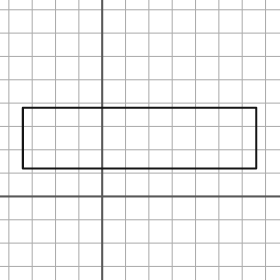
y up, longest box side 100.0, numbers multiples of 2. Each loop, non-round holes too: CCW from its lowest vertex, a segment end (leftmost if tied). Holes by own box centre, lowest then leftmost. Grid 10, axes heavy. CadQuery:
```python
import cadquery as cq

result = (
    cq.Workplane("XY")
    .moveTo(-34.0, 12.0)
    .lineTo(66.0, 12.0)
    .lineTo(66.0, 38.0)
    .lineTo(-34.0, 38.0)
    .close()
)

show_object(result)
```